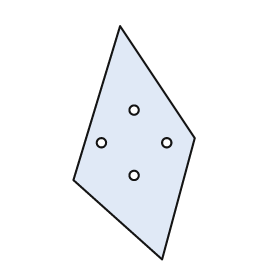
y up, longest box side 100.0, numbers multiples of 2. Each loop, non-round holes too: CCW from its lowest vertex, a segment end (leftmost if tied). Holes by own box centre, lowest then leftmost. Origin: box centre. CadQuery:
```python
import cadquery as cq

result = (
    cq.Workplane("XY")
    .moveTo(12.0, -50.0)
    .lineTo(26.0, 2.0)
    .lineTo(-6.0, 50.0)
    .lineTo(-26.0, -16.0)
    .close()
    .moveTo(0.0, -14.0)
    .circle(2.0)
    .moveTo(-14.0, 0.0)
    .circle(2.0)
    .moveTo(14.0, 0.0)
    .circle(2.0)
    .moveTo(0.0, 14.0)
    .circle(2.0)
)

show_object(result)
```